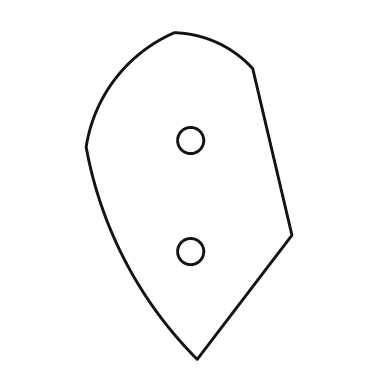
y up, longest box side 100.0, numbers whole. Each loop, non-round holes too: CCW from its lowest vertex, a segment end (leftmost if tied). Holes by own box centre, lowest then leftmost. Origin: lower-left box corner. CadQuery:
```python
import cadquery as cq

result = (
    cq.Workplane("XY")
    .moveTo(34.0, 0.0)
    .lineTo(63.0, 38.0)
    .lineTo(51.0, 89.0)
    .threePointArc((40.0, 97.0), (27.0, 100.0))
    .threePointArc((9.0, 86.0), (0.0, 65.0))
    .threePointArc((12.0, 30.0), (34.0, 0.0))
    .close()
    .moveTo(32.0, 33.0)
    .circle(4.0)
    .moveTo(32.0, 67.0)
    .circle(4.0)
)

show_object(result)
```